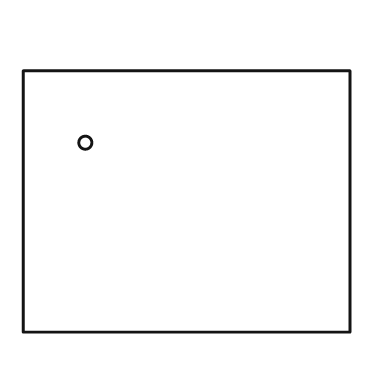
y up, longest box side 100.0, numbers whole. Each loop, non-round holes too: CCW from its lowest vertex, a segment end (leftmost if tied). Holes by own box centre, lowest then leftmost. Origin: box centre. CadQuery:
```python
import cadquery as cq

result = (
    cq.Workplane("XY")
    .moveTo(-50.0, -40.0)
    .lineTo(50.0, -40.0)
    .lineTo(50.0, 40.0)
    .lineTo(-50.0, 40.0)
    .close()
    .moveTo(-31.0, 18.0)
    .circle(2.0)
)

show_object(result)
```